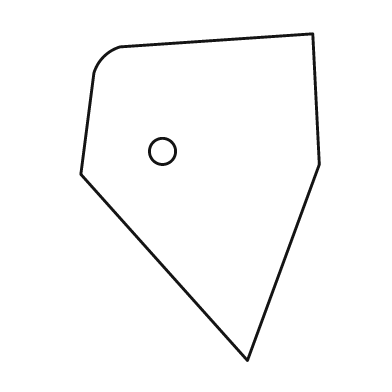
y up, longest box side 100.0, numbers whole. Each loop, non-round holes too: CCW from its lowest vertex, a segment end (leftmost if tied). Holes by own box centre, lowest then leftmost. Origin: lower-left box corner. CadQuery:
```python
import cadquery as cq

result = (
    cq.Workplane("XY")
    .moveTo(51.0, 0.0)
    .lineTo(73.0, 60.0)
    .lineTo(71.0, 100.0)
    .lineTo(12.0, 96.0)
    .threePointArc((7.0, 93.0), (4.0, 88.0))
    .lineTo(0.0, 57.0)
    .close()
    .moveTo(25.0, 64.0)
    .circle(4.0)
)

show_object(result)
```